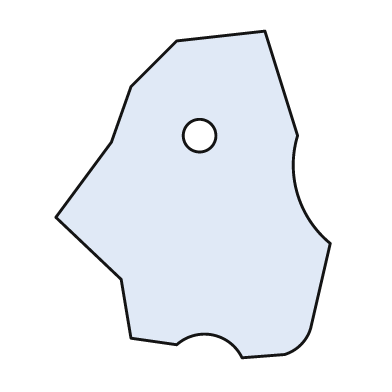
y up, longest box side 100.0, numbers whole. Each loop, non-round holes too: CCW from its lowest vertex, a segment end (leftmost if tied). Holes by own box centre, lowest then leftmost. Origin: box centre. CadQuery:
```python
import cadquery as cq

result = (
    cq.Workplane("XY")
    .moveTo(15.0, -50.0)
    .lineTo(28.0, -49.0)
    .threePointArc((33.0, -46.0), (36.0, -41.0))
    .lineTo(42.0, -15.0)
    .threePointArc((32.0, 0.0), (32.0, 18.0))
    .lineTo(22.0, 50.0)
    .lineTo(-5.0, 47.0)
    .lineTo(-19.0, 33.0)
    .lineTo(-25.0, 16.0)
    .lineTo(-42.0, -7.0)
    .lineTo(-22.0, -26.0)
    .lineTo(-19.0, -44.0)
    .lineTo(-5.0, -46.0)
    .threePointArc((6.0, -43.0), (15.0, -50.0))
    .close()
    .moveTo(2.0, 18.0)
    .circle(5.0)
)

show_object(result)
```